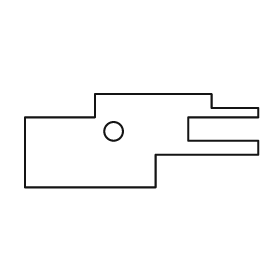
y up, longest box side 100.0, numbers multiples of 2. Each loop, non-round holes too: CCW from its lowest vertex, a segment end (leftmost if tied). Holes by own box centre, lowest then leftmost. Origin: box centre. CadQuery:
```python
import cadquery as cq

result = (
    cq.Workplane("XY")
    .moveTo(-50.0, -20.0)
    .lineTo(6.0, -20.0)
    .lineTo(6.0, -6.0)
    .lineTo(50.0, -6.0)
    .lineTo(50.0, 0.0)
    .lineTo(20.0, 0.0)
    .lineTo(20.0, 10.0)
    .lineTo(50.0, 10.0)
    .lineTo(50.0, 14.0)
    .lineTo(30.0, 14.0)
    .lineTo(30.0, 20.0)
    .lineTo(-20.0, 20.0)
    .lineTo(-20.0, 10.0)
    .lineTo(-50.0, 10.0)
    .close()
    .moveTo(-12.0, 4.0)
    .circle(4.0)
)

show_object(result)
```